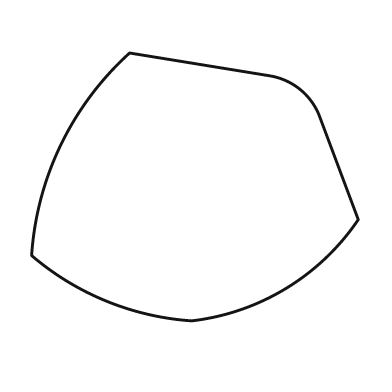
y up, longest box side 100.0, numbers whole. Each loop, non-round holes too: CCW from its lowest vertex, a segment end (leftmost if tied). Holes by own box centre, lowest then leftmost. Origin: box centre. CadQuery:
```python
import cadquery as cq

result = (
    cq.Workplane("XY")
    .moveTo(-1.0, -41.0)
    .threePointArc((28.0, -31.0), (50.0, -10.0))
    .lineTo(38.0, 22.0)
    .threePointArc((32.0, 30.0), (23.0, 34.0))
    .lineTo(-20.0, 41.0)
    .threePointArc((-41.0, 13.0), (-50.0, -21.0))
    .threePointArc((-27.0, -35.0), (-1.0, -41.0))
    .close()
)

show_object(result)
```